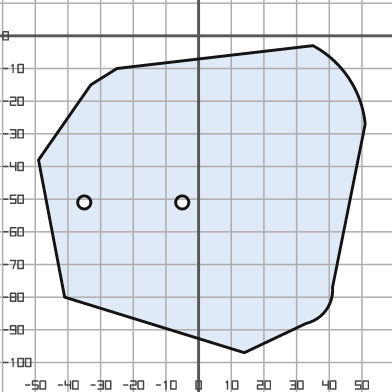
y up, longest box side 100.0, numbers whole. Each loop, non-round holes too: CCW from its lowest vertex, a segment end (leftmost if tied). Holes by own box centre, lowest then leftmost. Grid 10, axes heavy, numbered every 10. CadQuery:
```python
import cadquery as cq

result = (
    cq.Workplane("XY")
    .moveTo(14.0, -97.0)
    .lineTo(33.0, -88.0)
    .threePointArc((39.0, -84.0), (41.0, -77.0))
    .lineTo(51.0, -27.0)
    .threePointArc((46.0, -13.0), (35.0, -3.0))
    .lineTo(-25.0, -10.0)
    .lineTo(-33.0, -15.0)
    .lineTo(-49.0, -38.0)
    .lineTo(-41.0, -80.0)
    .close()
    .moveTo(-35.0, -51.0)
    .circle(2.0)
    .moveTo(-5.0, -51.0)
    .circle(2.0)
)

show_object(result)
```